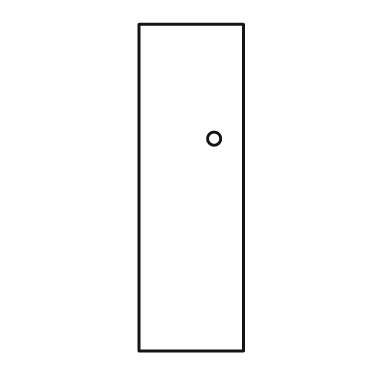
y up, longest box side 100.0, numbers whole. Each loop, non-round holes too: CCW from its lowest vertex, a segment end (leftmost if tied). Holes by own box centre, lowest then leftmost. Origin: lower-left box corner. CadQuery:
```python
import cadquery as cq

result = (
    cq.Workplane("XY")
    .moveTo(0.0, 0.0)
    .lineTo(32.0, 0.0)
    .lineTo(32.0, 100.0)
    .lineTo(0.0, 100.0)
    .close()
    .moveTo(23.0, 65.0)
    .circle(2.0)
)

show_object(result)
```